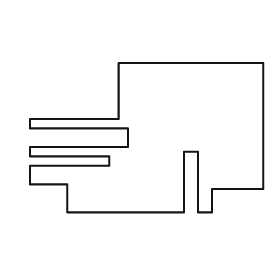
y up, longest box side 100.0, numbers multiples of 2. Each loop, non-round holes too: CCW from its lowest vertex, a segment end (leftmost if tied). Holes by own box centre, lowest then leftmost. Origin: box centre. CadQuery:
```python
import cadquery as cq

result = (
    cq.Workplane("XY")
    .moveTo(-34.0, -32.0)
    .lineTo(16.0, -32.0)
    .lineTo(16.0, -6.0)
    .lineTo(22.0, -6.0)
    .lineTo(22.0, -32.0)
    .lineTo(28.0, -32.0)
    .lineTo(28.0, -22.0)
    .lineTo(50.0, -22.0)
    .lineTo(50.0, 32.0)
    .lineTo(-12.0, 32.0)
    .lineTo(-12.0, 8.0)
    .lineTo(-50.0, 8.0)
    .lineTo(-50.0, 4.0)
    .lineTo(-8.0, 4.0)
    .lineTo(-8.0, -4.0)
    .lineTo(-50.0, -4.0)
    .lineTo(-50.0, -8.0)
    .lineTo(-16.0, -8.0)
    .lineTo(-16.0, -12.0)
    .lineTo(-50.0, -12.0)
    .lineTo(-50.0, -20.0)
    .lineTo(-34.0, -20.0)
    .close()
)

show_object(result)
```